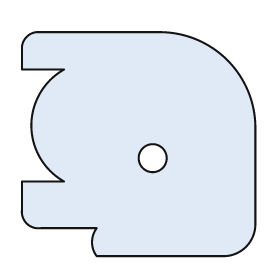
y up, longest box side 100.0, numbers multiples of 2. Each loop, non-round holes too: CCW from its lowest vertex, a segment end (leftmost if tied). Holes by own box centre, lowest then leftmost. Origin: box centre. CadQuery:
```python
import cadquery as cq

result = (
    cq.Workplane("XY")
    .moveTo(-18.0, -48.0)
    .lineTo(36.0, -48.0)
    .threePointArc((46.0, -44.0), (50.0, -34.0))
    .lineTo(50.0, 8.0)
    .threePointArc((38.0, 36.0), (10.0, 48.0))
    .lineTo(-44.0, 48.0)
    .threePointArc((-48.0, 46.0), (-50.0, 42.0))
    .lineTo(-50.0, 32.0)
    .lineTo(-32.0, 32.0)
    .threePointArc((-46.0, 8.0), (-32.0, -16.0))
    .lineTo(-50.0, -16.0)
    .lineTo(-50.0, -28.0)
    .threePointArc((-48.0, -34.0), (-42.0, -36.0))
    .lineTo(-18.0, -36.0)
    .threePointArc((-20.0, -42.0), (-18.0, -48.0))
    .close()
    .moveTo(6.0, -6.0)
    .circle(6.0)
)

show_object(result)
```